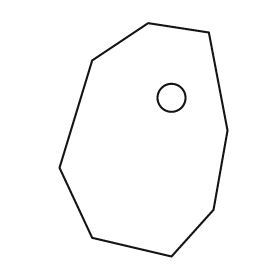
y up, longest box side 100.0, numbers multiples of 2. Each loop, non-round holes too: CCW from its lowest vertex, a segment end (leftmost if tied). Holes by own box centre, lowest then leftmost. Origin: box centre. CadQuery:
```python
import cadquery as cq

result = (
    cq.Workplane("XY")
    .moveTo(12.0, -50.0)
    .lineTo(30.0, -30.0)
    .lineTo(36.0, 4.0)
    .lineTo(28.0, 46.0)
    .lineTo(2.0, 50.0)
    .lineTo(-22.0, 34.0)
    .lineTo(-36.0, -12.0)
    .lineTo(-22.0, -42.0)
    .close()
    .moveTo(12.0, 18.0)
    .circle(6.0)
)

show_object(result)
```